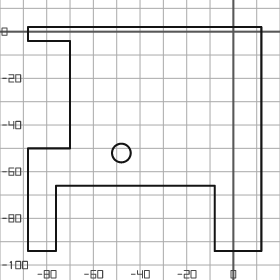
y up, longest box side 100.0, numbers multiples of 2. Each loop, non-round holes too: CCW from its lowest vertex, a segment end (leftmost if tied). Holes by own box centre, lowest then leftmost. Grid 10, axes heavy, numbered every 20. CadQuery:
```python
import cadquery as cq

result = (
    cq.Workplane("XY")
    .moveTo(-88.0, -94.0)
    .lineTo(-76.0, -94.0)
    .lineTo(-76.0, -66.0)
    .lineTo(-8.0, -66.0)
    .lineTo(-8.0, -94.0)
    .lineTo(12.0, -94.0)
    .lineTo(12.0, 2.0)
    .lineTo(-88.0, 2.0)
    .lineTo(-88.0, -4.0)
    .lineTo(-70.0, -4.0)
    .lineTo(-70.0, -50.0)
    .lineTo(-88.0, -50.0)
    .close()
    .moveTo(-48.0, -52.0)
    .circle(4.0)
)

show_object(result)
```